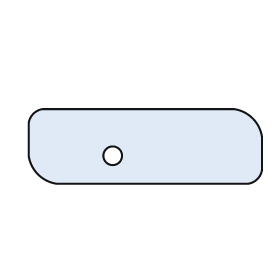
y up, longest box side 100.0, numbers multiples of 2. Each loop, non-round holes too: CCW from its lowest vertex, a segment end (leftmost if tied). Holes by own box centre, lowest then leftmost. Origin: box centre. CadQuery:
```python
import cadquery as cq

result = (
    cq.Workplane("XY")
    .moveTo(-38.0, -16.0)
    .lineTo(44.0, -16.0)
    .threePointArc((48.0, -14.0), (50.0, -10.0))
    .lineTo(50.0, 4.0)
    .threePointArc((46.0, 12.0), (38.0, 16.0))
    .lineTo(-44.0, 16.0)
    .threePointArc((-48.0, 14.0), (-50.0, 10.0))
    .lineTo(-50.0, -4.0)
    .threePointArc((-46.0, -12.0), (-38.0, -16.0))
    .close()
    .moveTo(-14.0, -4.0)
    .circle(4.0)
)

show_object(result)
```